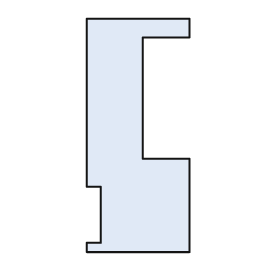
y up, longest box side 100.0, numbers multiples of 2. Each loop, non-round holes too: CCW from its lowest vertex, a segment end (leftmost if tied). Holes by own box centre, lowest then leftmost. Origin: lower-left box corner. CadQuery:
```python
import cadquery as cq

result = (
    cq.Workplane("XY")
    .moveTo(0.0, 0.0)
    .lineTo(44.0, 0.0)
    .lineTo(44.0, 40.0)
    .lineTo(24.0, 40.0)
    .lineTo(24.0, 92.0)
    .lineTo(44.0, 92.0)
    .lineTo(44.0, 100.0)
    .lineTo(0.0, 100.0)
    .lineTo(0.0, 28.0)
    .lineTo(6.0, 28.0)
    .lineTo(6.0, 4.0)
    .lineTo(0.0, 4.0)
    .close()
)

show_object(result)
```